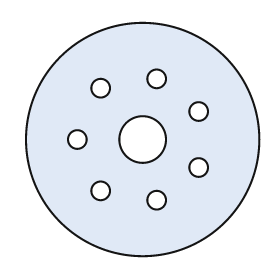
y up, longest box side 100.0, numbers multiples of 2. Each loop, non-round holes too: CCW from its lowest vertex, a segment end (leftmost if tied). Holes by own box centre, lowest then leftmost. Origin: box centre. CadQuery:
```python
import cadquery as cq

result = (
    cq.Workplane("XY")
    .moveTo(0.0, 0.0)
    .circle(50.0)
    .moveTo(6.0, -26.0)
    .circle(4.0)
    .moveTo(-18.0, -22.0)
    .circle(4.0)
    .moveTo(24.0, -12.0)
    .circle(4.0)
    .moveTo(-28.0, 0.0)
    .circle(4.0)
    .moveTo(0.0, 0.0)
    .circle(10.0)
    .moveTo(24.0, 12.0)
    .circle(4.0)
    .moveTo(-18.0, 22.0)
    .circle(4.0)
    .moveTo(6.0, 26.0)
    .circle(4.0)
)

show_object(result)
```